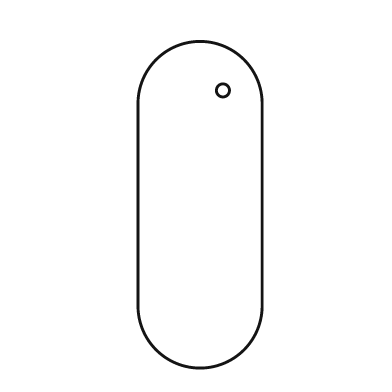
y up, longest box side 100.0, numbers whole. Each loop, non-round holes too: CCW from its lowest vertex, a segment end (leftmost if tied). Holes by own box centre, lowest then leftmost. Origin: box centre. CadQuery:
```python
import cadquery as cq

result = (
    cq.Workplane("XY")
    .moveTo(-19.0, -31.0)
    .threePointArc((0.0, -50.0), (19.0, -31.0))
    .lineTo(19.0, 31.0)
    .threePointArc((0.0, 50.0), (-19.0, 31.0))
    .close()
    .moveTo(7.0, 35.0)
    .circle(2.0)
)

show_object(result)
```